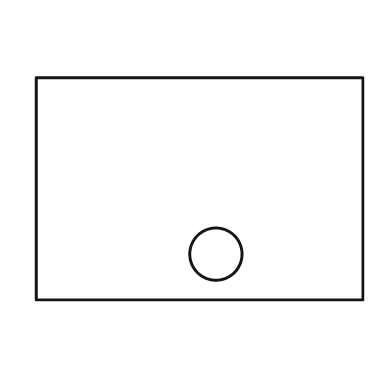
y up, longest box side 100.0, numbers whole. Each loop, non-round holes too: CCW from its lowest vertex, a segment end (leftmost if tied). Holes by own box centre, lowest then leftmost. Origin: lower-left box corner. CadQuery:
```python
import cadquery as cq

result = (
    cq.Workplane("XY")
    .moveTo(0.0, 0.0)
    .lineTo(100.0, 0.0)
    .lineTo(100.0, 68.0)
    .lineTo(0.0, 68.0)
    .close()
    .moveTo(55.0, 14.0)
    .circle(8.0)
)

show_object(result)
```